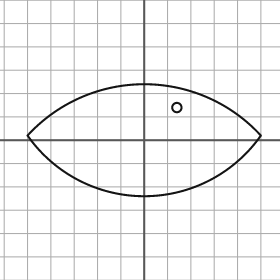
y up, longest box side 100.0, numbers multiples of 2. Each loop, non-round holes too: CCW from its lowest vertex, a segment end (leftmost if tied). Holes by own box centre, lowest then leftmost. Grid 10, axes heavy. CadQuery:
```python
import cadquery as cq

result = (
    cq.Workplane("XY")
    .moveTo(-50.0, 2.0)
    .threePointArc((0.0, -24.0), (50.0, 2.0))
    .threePointArc((0.0, 24.0), (-50.0, 2.0))
    .close()
    .moveTo(14.0, 14.0)
    .circle(2.0)
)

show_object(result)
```